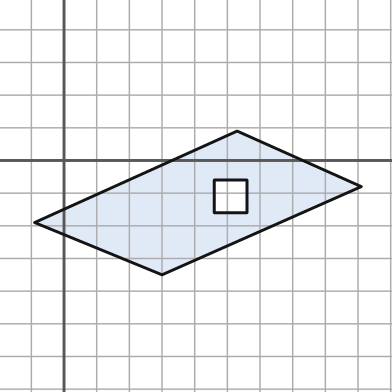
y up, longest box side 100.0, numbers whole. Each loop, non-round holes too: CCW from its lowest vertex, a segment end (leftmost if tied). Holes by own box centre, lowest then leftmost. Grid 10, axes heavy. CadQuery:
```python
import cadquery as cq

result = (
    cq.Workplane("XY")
    .moveTo(30.0, -35.0)
    .lineTo(91.0, -8.0)
    .lineTo(53.0, 9.0)
    .lineTo(-9.0, -19.0)
    .close()
    .moveTo(46.0, -16.0)
    .lineTo(56.0, -16.0)
    .lineTo(56.0, -6.0)
    .lineTo(46.0, -6.0)
    .close()
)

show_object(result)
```